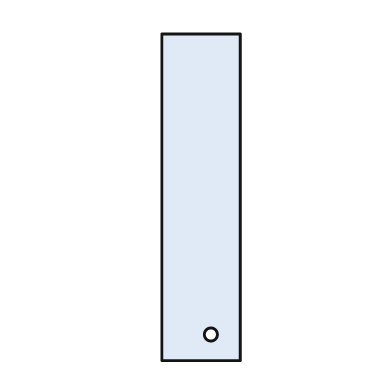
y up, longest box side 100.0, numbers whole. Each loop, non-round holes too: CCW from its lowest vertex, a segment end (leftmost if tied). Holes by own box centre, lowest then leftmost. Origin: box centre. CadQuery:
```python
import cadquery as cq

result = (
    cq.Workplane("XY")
    .moveTo(-12.0, -50.0)
    .lineTo(12.0, -50.0)
    .lineTo(12.0, 50.0)
    .lineTo(-12.0, 50.0)
    .close()
    .moveTo(3.0, -42.0)
    .circle(2.0)
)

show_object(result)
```